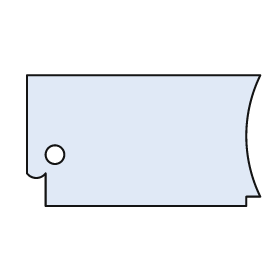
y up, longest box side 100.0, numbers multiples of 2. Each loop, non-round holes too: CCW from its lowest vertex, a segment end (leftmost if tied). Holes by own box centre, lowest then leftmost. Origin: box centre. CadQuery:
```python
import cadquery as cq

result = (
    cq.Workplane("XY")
    .moveTo(-42.0, -28.0)
    .lineTo(44.0, -28.0)
    .lineTo(44.0, -24.0)
    .lineTo(50.0, -24.0)
    .threePointArc((44.0, 2.0), (50.0, 28.0))
    .lineTo(-50.0, 28.0)
    .lineTo(-50.0, -14.0)
    .threePointArc((-46.0, -16.0), (-42.0, -14.0))
    .close()
    .moveTo(-38.0, -6.0)
    .circle(4.0)
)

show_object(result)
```